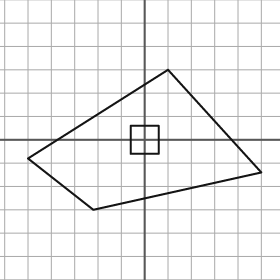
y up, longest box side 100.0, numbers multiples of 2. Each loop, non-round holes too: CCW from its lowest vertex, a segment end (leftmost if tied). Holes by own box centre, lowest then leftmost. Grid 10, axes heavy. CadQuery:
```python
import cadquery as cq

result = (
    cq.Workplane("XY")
    .moveTo(-22.0, -30.0)
    .lineTo(50.0, -14.0)
    .lineTo(10.0, 30.0)
    .lineTo(-50.0, -8.0)
    .close()
    .moveTo(-6.0, -6.0)
    .lineTo(6.0, -6.0)
    .lineTo(6.0, 6.0)
    .lineTo(-6.0, 6.0)
    .close()
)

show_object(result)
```